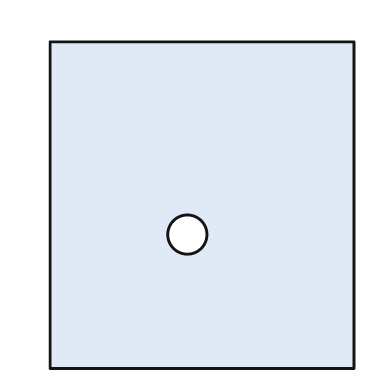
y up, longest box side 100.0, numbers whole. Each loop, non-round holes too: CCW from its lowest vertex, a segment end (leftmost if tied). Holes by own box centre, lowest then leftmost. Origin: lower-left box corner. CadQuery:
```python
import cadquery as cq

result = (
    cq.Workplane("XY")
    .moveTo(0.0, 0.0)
    .lineTo(93.0, 0.0)
    .lineTo(93.0, 100.0)
    .lineTo(0.0, 100.0)
    .close()
    .moveTo(42.0, 41.0)
    .circle(6.0)
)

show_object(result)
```